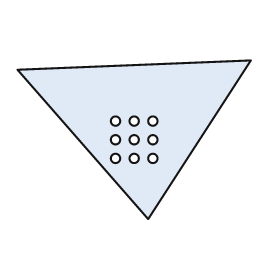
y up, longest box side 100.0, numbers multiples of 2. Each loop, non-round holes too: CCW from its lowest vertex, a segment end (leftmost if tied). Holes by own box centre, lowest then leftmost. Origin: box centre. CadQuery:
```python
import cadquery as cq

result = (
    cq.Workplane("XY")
    .moveTo(6.0, -34.0)
    .lineTo(50.0, 34.0)
    .lineTo(-50.0, 30.0)
    .close()
    .moveTo(-8.0, -8.0)
    .circle(2.0)
    .moveTo(0.0, -8.0)
    .circle(2.0)
    .moveTo(8.0, -8.0)
    .circle(2.0)
    .moveTo(-8.0, 0.0)
    .circle(2.0)
    .moveTo(0.0, 0.0)
    .circle(2.0)
    .moveTo(8.0, 0.0)
    .circle(2.0)
    .moveTo(-8.0, 8.0)
    .circle(2.0)
    .moveTo(0.0, 8.0)
    .circle(2.0)
    .moveTo(8.0, 8.0)
    .circle(2.0)
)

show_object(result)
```